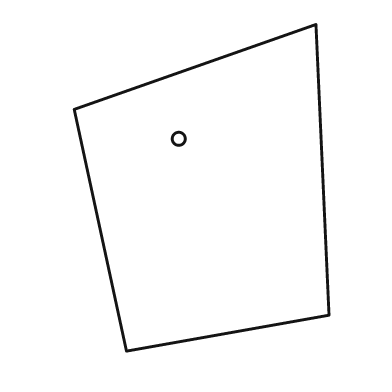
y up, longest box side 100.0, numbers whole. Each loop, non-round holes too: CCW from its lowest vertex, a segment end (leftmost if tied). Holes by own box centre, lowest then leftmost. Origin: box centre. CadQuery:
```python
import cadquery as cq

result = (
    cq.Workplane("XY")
    .moveTo(-23.0, -50.0)
    .lineTo(39.0, -39.0)
    .lineTo(35.0, 50.0)
    .lineTo(-39.0, 24.0)
    .close()
    .moveTo(-7.0, 15.0)
    .circle(2.0)
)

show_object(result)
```